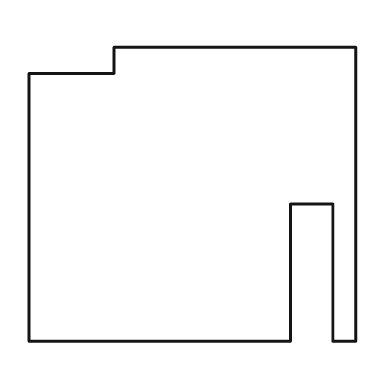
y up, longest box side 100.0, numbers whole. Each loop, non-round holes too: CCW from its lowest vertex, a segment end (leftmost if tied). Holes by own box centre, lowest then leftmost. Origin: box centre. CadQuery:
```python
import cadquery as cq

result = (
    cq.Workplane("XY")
    .moveTo(-50.0, -45.0)
    .lineTo(30.0, -45.0)
    .lineTo(30.0, -3.0)
    .lineTo(43.0, -3.0)
    .lineTo(43.0, -45.0)
    .lineTo(50.0, -45.0)
    .lineTo(50.0, 45.0)
    .lineTo(-24.0, 45.0)
    .lineTo(-24.0, 37.0)
    .lineTo(-50.0, 37.0)
    .close()
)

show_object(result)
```